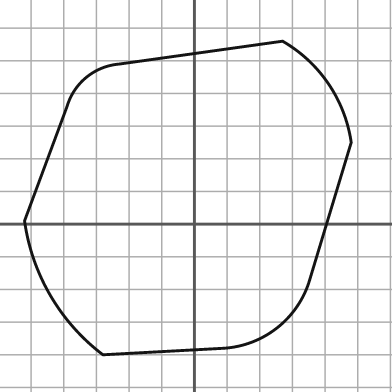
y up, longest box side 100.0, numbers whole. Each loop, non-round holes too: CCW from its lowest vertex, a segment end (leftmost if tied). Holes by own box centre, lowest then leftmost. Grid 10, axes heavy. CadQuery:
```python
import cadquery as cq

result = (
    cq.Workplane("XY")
    .moveTo(-28.0, -40.0)
    .lineTo(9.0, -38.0)
    .threePointArc((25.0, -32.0), (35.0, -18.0))
    .lineTo(48.0, 25.0)
    .threePointArc((41.0, 43.0), (27.0, 56.0))
    .lineTo(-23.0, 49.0)
    .threePointArc((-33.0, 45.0), (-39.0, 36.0))
    .lineTo(-52.0, 1.0)
    .threePointArc((-44.0, -22.0), (-28.0, -40.0))
    .close()
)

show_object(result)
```